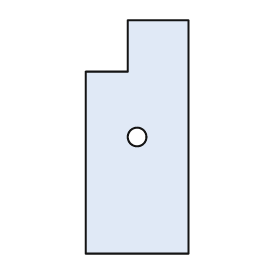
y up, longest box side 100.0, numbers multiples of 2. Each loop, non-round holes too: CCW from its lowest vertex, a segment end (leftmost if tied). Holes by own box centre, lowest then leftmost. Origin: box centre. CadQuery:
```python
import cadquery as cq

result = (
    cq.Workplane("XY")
    .moveTo(-22.0, -50.0)
    .lineTo(22.0, -50.0)
    .lineTo(22.0, 50.0)
    .lineTo(-4.0, 50.0)
    .lineTo(-4.0, 28.0)
    .lineTo(-22.0, 28.0)
    .close()
    .moveTo(0.0, 0.0)
    .circle(4.0)
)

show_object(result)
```